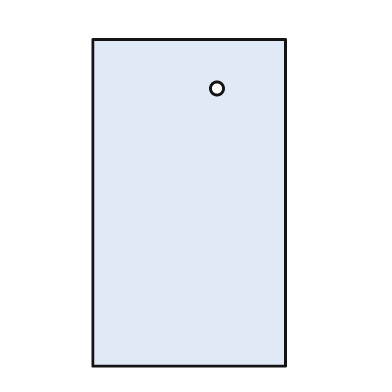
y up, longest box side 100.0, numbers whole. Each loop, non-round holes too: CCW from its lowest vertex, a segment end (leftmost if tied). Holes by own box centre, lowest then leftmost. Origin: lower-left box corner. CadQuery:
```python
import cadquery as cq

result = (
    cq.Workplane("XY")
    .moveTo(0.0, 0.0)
    .lineTo(59.0, 0.0)
    .lineTo(59.0, 100.0)
    .lineTo(0.0, 100.0)
    .close()
    .moveTo(38.0, 85.0)
    .circle(2.0)
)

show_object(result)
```